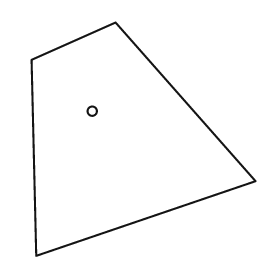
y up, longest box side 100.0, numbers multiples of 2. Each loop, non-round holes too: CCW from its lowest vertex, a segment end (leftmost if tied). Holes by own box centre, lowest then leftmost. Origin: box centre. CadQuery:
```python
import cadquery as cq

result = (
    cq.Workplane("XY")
    .moveTo(-46.0, -50.0)
    .lineTo(48.0, -18.0)
    .lineTo(-12.0, 50.0)
    .lineTo(-48.0, 34.0)
    .close()
    .moveTo(-22.0, 12.0)
    .circle(2.0)
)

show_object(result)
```